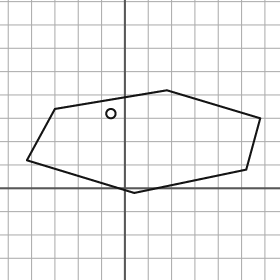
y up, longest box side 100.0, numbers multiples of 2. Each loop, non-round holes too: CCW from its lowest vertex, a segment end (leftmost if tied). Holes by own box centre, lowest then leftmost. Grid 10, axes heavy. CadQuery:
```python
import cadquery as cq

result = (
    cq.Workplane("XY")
    .moveTo(4.0, -2.0)
    .lineTo(52.0, 8.0)
    .lineTo(58.0, 30.0)
    .lineTo(18.0, 42.0)
    .lineTo(-30.0, 34.0)
    .lineTo(-42.0, 12.0)
    .close()
    .moveTo(-6.0, 32.0)
    .circle(2.0)
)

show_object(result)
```